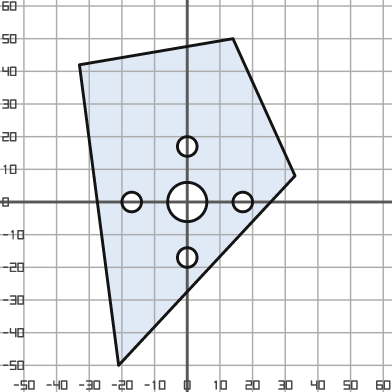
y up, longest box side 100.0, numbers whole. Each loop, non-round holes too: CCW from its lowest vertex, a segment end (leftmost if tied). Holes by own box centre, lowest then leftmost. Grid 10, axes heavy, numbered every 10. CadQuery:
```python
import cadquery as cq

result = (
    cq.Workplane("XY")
    .moveTo(-21.0, -50.0)
    .lineTo(33.0, 8.0)
    .lineTo(14.0, 50.0)
    .lineTo(-33.0, 42.0)
    .close()
    .moveTo(0.0, -17.0)
    .circle(3.0)
    .moveTo(-17.0, 0.0)
    .circle(3.0)
    .moveTo(0.0, 0.0)
    .circle(6.0)
    .moveTo(17.0, 0.0)
    .circle(3.0)
    .moveTo(0.0, 17.0)
    .circle(3.0)
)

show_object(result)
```